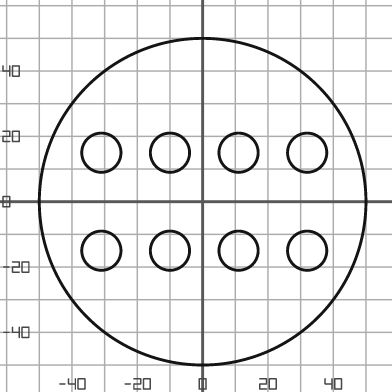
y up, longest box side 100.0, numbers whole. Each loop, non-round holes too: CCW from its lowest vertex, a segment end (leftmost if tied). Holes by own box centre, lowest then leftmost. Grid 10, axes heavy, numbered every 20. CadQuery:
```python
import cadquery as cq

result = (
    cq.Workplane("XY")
    .moveTo(0.0, 0.0)
    .circle(50.0)
    .moveTo(-31.0, -15.0)
    .circle(6.0)
    .moveTo(-10.0, -15.0)
    .circle(6.0)
    .moveTo(11.0, -15.0)
    .circle(6.0)
    .moveTo(32.0, -15.0)
    .circle(6.0)
    .moveTo(-31.0, 15.0)
    .circle(6.0)
    .moveTo(-10.0, 15.0)
    .circle(6.0)
    .moveTo(11.0, 15.0)
    .circle(6.0)
    .moveTo(32.0, 15.0)
    .circle(6.0)
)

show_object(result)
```